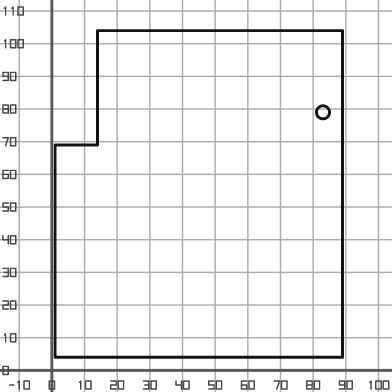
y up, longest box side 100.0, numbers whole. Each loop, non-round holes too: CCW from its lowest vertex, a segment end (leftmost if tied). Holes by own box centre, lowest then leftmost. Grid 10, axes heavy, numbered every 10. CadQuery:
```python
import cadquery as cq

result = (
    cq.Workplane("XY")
    .moveTo(1.0, 4.0)
    .lineTo(89.0, 4.0)
    .lineTo(89.0, 104.0)
    .lineTo(14.0, 104.0)
    .lineTo(14.0, 69.0)
    .lineTo(1.0, 69.0)
    .close()
    .moveTo(83.0, 79.0)
    .circle(2.0)
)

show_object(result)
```